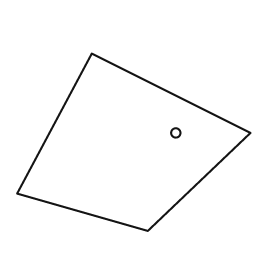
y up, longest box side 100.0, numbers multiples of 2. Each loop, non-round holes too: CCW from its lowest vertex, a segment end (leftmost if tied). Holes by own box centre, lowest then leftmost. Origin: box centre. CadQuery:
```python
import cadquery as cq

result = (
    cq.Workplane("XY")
    .moveTo(6.0, -38.0)
    .lineTo(50.0, 4.0)
    .lineTo(-18.0, 38.0)
    .lineTo(-50.0, -22.0)
    .close()
    .moveTo(18.0, 4.0)
    .circle(2.0)
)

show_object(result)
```